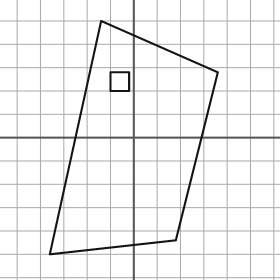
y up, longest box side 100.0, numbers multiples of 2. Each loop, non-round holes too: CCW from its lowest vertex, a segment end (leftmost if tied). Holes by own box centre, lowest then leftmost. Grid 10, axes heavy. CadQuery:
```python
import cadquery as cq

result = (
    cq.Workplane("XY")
    .moveTo(-36.0, -50.0)
    .lineTo(18.0, -44.0)
    .lineTo(36.0, 28.0)
    .lineTo(-14.0, 50.0)
    .close()
    .moveTo(-10.0, 20.0)
    .lineTo(-2.0, 20.0)
    .lineTo(-2.0, 28.0)
    .lineTo(-10.0, 28.0)
    .close()
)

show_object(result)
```